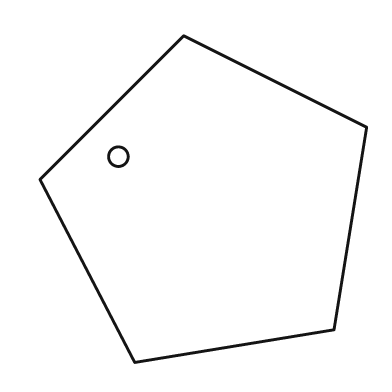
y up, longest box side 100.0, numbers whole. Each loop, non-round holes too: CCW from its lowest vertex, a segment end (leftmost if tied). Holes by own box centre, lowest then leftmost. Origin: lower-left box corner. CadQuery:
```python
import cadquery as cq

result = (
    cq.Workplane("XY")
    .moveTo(29.0, 0.0)
    .lineTo(90.0, 10.0)
    .lineTo(100.0, 72.0)
    .lineTo(44.0, 100.0)
    .lineTo(0.0, 56.0)
    .close()
    .moveTo(24.0, 63.0)
    .circle(3.0)
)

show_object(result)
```